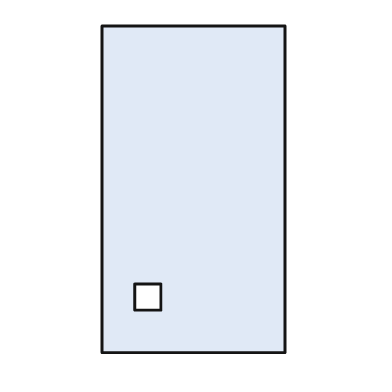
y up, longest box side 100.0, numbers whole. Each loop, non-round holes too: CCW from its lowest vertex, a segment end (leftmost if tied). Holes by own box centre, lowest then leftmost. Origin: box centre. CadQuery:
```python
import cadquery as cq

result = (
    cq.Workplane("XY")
    .moveTo(-28.0, -50.0)
    .lineTo(28.0, -50.0)
    .lineTo(28.0, 50.0)
    .lineTo(-28.0, 50.0)
    .close()
    .moveTo(-18.0, -37.0)
    .lineTo(-10.0, -37.0)
    .lineTo(-10.0, -29.0)
    .lineTo(-18.0, -29.0)
    .close()
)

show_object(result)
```